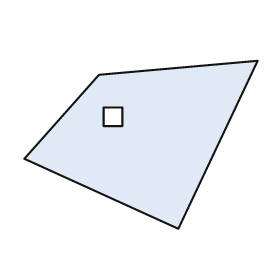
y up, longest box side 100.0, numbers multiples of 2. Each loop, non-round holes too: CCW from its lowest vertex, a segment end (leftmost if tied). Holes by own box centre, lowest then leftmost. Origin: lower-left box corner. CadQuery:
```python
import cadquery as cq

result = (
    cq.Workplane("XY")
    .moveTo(66.0, 0.0)
    .lineTo(100.0, 72.0)
    .lineTo(32.0, 66.0)
    .lineTo(0.0, 30.0)
    .close()
    .moveTo(34.0, 44.0)
    .lineTo(42.0, 44.0)
    .lineTo(42.0, 52.0)
    .lineTo(34.0, 52.0)
    .close()
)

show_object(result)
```